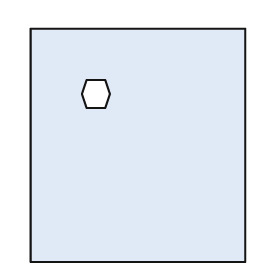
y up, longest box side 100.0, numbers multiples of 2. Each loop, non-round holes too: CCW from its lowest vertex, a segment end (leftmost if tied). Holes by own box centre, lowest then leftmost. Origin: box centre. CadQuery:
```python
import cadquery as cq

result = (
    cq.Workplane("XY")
    .moveTo(-46.0, -50.0)
    .lineTo(46.0, -50.0)
    .lineTo(46.0, 50.0)
    .lineTo(-46.0, 50.0)
    .close()
    .moveTo(-22.0, 16.0)
    .lineTo(-14.0, 16.0)
    .lineTo(-12.0, 22.0)
    .lineTo(-14.0, 28.0)
    .lineTo(-22.0, 28.0)
    .lineTo(-24.0, 22.0)
    .close()
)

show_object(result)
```